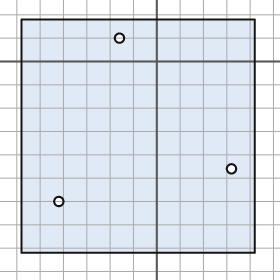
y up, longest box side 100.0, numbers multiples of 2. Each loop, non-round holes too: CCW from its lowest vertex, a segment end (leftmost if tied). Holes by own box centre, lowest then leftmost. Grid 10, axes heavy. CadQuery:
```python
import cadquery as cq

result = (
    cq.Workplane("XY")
    .moveTo(-58.0, -82.0)
    .lineTo(42.0, -82.0)
    .lineTo(42.0, 18.0)
    .lineTo(-58.0, 18.0)
    .close()
    .moveTo(-42.0, -60.0)
    .circle(2.0)
    .moveTo(32.0, -46.0)
    .circle(2.0)
    .moveTo(-16.0, 10.0)
    .circle(2.0)
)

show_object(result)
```